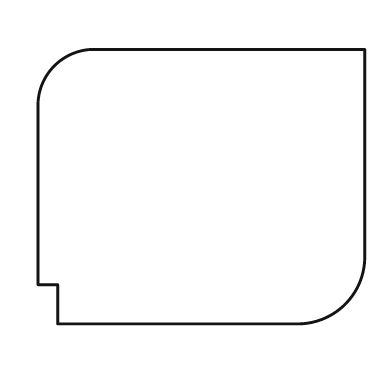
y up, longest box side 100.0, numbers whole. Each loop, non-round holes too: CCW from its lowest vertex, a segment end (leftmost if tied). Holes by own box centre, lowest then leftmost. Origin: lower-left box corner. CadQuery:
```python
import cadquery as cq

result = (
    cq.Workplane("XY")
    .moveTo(6.0, 0.0)
    .lineTo(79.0, 0.0)
    .threePointArc((94.0, 6.0), (100.0, 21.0))
    .lineTo(100.0, 84.0)
    .lineTo(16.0, 84.0)
    .threePointArc((5.0, 79.0), (0.0, 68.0))
    .lineTo(0.0, 12.0)
    .lineTo(6.0, 12.0)
    .close()
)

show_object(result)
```